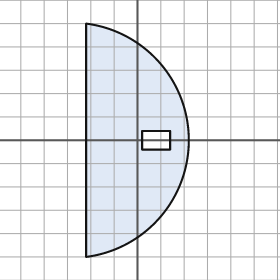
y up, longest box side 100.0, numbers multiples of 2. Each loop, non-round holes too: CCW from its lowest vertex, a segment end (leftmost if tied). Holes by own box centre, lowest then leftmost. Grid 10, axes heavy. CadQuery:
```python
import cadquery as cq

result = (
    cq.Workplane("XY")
    .moveTo(-22.0, -50.0)
    .threePointArc((22.0, 0.0), (-22.0, 50.0))
    .close()
    .moveTo(2.0, -4.0)
    .lineTo(14.0, -4.0)
    .lineTo(14.0, 4.0)
    .lineTo(2.0, 4.0)
    .close()
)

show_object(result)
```